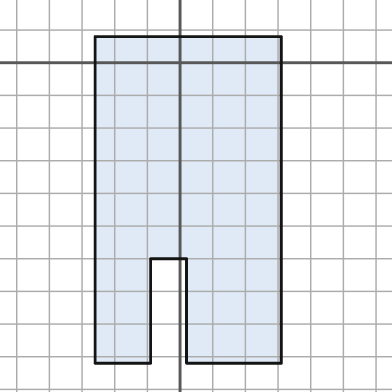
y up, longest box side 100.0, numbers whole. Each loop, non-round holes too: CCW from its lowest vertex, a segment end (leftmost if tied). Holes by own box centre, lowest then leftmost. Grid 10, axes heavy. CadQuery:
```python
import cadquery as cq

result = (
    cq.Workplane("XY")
    .moveTo(-26.0, -92.0)
    .lineTo(-9.0, -92.0)
    .lineTo(-9.0, -60.0)
    .lineTo(2.0, -60.0)
    .lineTo(2.0, -92.0)
    .lineTo(31.0, -92.0)
    .lineTo(31.0, 8.0)
    .lineTo(-26.0, 8.0)
    .close()
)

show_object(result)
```